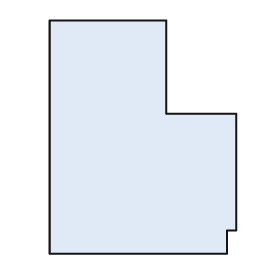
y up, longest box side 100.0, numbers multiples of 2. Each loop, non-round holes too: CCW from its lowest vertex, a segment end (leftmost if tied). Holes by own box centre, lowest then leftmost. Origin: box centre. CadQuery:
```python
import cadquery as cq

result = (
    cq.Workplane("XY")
    .moveTo(-40.0, -50.0)
    .lineTo(36.0, -50.0)
    .lineTo(36.0, -40.0)
    .lineTo(40.0, -40.0)
    .lineTo(40.0, 10.0)
    .lineTo(10.0, 10.0)
    .lineTo(10.0, 50.0)
    .lineTo(-40.0, 50.0)
    .close()
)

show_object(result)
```